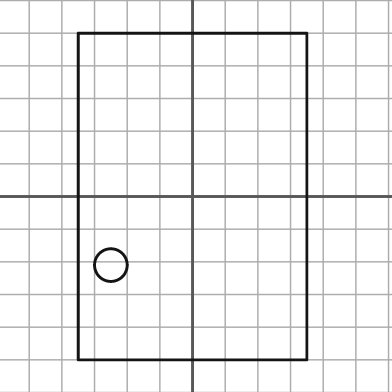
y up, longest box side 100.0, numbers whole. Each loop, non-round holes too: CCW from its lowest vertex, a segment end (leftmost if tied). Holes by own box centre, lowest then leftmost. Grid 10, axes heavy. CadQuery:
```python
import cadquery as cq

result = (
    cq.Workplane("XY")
    .moveTo(-35.0, -50.0)
    .lineTo(35.0, -50.0)
    .lineTo(35.0, 50.0)
    .lineTo(-35.0, 50.0)
    .close()
    .moveTo(-25.0, -21.0)
    .circle(5.0)
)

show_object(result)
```